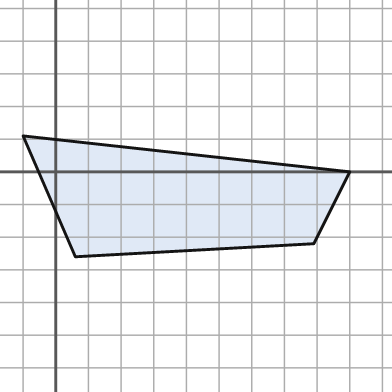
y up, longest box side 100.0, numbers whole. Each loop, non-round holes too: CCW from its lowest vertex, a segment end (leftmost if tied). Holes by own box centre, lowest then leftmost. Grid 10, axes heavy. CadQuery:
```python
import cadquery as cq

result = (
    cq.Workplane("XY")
    .moveTo(6.0, -26.0)
    .lineTo(79.0, -22.0)
    .lineTo(90.0, 0.0)
    .lineTo(-10.0, 11.0)
    .close()
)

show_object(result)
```